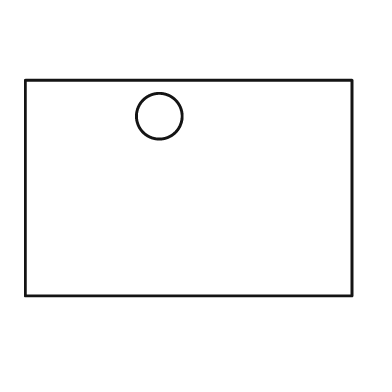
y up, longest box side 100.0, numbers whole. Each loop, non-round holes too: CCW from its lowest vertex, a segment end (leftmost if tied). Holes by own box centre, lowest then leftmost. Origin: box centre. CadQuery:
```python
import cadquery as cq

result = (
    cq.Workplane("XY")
    .moveTo(-50.0, -33.0)
    .lineTo(50.0, -33.0)
    .lineTo(50.0, 33.0)
    .lineTo(-50.0, 33.0)
    .close()
    .moveTo(-9.0, 22.0)
    .circle(7.0)
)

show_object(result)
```